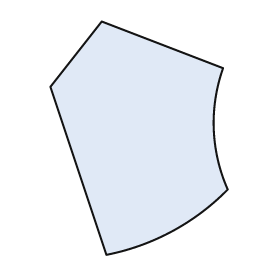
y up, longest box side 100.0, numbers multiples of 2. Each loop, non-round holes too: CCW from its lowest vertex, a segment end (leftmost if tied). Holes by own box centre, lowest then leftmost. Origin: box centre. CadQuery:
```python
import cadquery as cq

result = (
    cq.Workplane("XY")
    .moveTo(-14.0, -50.0)
    .threePointArc((14.0, -40.0), (38.0, -22.0))
    .threePointArc((32.0, 4.0), (36.0, 30.0))
    .lineTo(-16.0, 50.0)
    .lineTo(-38.0, 22.0)
    .close()
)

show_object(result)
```